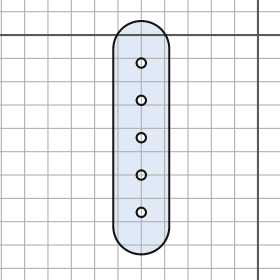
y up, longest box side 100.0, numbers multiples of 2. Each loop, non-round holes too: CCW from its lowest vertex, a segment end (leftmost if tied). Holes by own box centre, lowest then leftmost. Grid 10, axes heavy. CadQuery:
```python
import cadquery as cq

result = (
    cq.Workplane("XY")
    .moveTo(-62.0, -82.0)
    .threePointArc((-50.0, -94.0), (-38.0, -82.0))
    .lineTo(-38.0, -6.0)
    .threePointArc((-50.0, 6.0), (-62.0, -6.0))
    .close()
    .moveTo(-50.0, -76.0)
    .circle(2.0)
    .moveTo(-50.0, -60.0)
    .circle(2.0)
    .moveTo(-50.0, -44.0)
    .circle(2.0)
    .moveTo(-50.0, -28.0)
    .circle(2.0)
    .moveTo(-50.0, -12.0)
    .circle(2.0)
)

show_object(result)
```